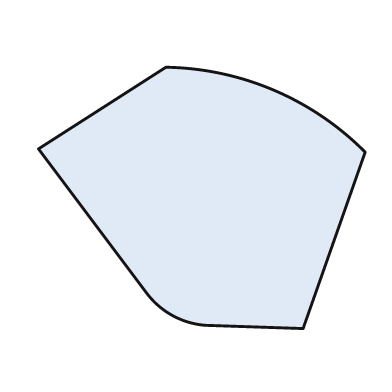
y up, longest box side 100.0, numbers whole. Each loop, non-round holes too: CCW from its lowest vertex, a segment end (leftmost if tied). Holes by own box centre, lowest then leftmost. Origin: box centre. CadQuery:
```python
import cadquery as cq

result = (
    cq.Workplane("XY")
    .moveTo(31.0, -40.0)
    .lineTo(50.0, 14.0)
    .threePointArc((22.0, 33.0), (-11.0, 40.0))
    .lineTo(-50.0, 15.0)
    .lineTo(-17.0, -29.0)
    .threePointArc((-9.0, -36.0), (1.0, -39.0))
    .close()
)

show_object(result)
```